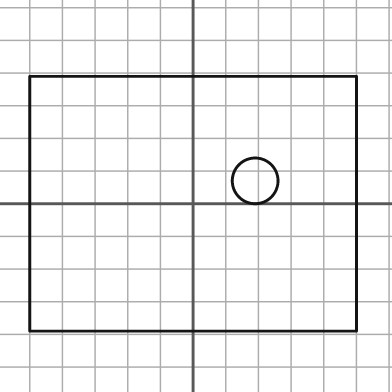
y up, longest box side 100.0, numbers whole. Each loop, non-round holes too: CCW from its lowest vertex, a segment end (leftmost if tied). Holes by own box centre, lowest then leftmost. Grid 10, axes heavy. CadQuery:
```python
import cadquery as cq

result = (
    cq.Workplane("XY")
    .moveTo(-50.0, -39.0)
    .lineTo(50.0, -39.0)
    .lineTo(50.0, 39.0)
    .lineTo(-50.0, 39.0)
    .close()
    .moveTo(19.0, 7.0)
    .circle(7.0)
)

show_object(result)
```